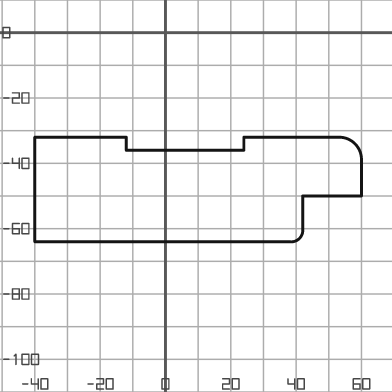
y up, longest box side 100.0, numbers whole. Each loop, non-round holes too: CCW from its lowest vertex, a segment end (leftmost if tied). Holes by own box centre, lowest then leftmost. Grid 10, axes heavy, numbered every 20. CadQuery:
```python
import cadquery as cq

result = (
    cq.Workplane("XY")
    .moveTo(-40.0, -64.0)
    .lineTo(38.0, -64.0)
    .threePointArc((41.0, -63.0), (42.0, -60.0))
    .lineTo(42.0, -50.0)
    .lineTo(60.0, -50.0)
    .lineTo(60.0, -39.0)
    .threePointArc((58.0, -34.0), (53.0, -32.0))
    .lineTo(24.0, -32.0)
    .lineTo(24.0, -36.0)
    .lineTo(-12.0, -36.0)
    .lineTo(-12.0, -32.0)
    .lineTo(-40.0, -32.0)
    .close()
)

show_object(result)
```